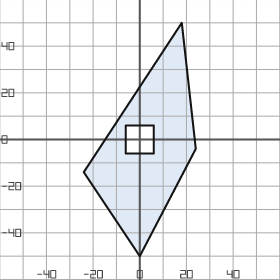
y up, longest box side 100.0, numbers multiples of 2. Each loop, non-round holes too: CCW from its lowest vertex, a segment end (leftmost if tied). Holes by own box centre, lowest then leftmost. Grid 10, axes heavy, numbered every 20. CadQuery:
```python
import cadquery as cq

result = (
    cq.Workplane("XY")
    .moveTo(0.0, -50.0)
    .lineTo(24.0, -4.0)
    .lineTo(18.0, 50.0)
    .lineTo(-24.0, -14.0)
    .close()
    .moveTo(-6.0, -6.0)
    .lineTo(6.0, -6.0)
    .lineTo(6.0, 6.0)
    .lineTo(-6.0, 6.0)
    .close()
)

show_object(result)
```